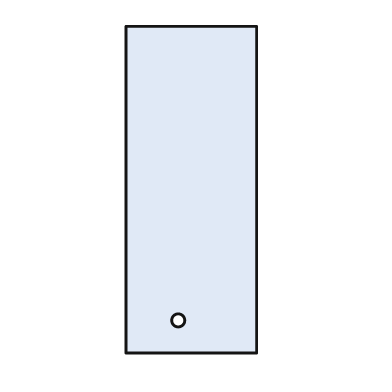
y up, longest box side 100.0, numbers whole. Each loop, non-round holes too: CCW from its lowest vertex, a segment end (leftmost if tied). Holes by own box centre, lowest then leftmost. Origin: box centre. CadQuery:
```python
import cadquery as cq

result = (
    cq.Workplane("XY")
    .moveTo(-20.0, -50.0)
    .lineTo(20.0, -50.0)
    .lineTo(20.0, 50.0)
    .lineTo(-20.0, 50.0)
    .close()
    .moveTo(-4.0, -40.0)
    .circle(2.0)
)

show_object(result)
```